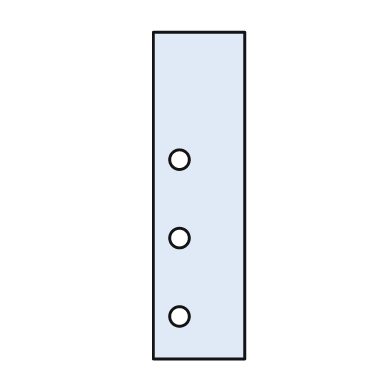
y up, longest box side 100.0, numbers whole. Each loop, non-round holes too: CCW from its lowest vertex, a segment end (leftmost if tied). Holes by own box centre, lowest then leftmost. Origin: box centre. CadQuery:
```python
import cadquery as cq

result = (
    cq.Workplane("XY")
    .moveTo(-14.0, -50.0)
    .lineTo(14.0, -50.0)
    .lineTo(14.0, 50.0)
    .lineTo(-14.0, 50.0)
    .close()
    .moveTo(-6.0, -37.0)
    .circle(3.0)
    .moveTo(-6.0, -13.0)
    .circle(3.0)
    .moveTo(-6.0, 11.0)
    .circle(3.0)
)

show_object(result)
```